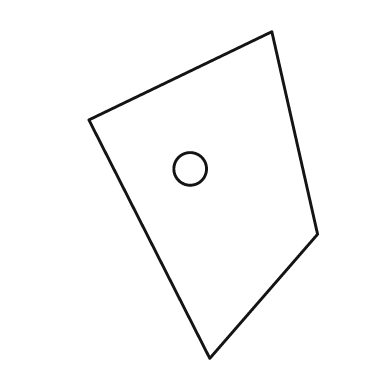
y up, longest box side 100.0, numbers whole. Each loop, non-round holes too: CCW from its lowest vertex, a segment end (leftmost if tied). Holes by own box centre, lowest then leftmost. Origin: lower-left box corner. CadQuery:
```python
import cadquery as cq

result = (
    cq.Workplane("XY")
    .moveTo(37.0, 0.0)
    .lineTo(70.0, 38.0)
    .lineTo(56.0, 100.0)
    .lineTo(0.0, 73.0)
    .close()
    .moveTo(31.0, 58.0)
    .circle(5.0)
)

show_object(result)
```